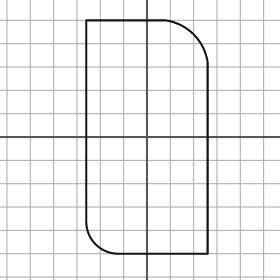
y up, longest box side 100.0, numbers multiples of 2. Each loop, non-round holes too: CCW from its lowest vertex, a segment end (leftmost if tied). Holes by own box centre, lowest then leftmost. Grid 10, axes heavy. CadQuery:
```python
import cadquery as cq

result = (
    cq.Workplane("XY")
    .moveTo(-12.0, -50.0)
    .lineTo(26.0, -50.0)
    .lineTo(26.0, 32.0)
    .threePointArc((20.0, 44.0), (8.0, 50.0))
    .lineTo(-26.0, 50.0)
    .lineTo(-26.0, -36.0)
    .threePointArc((-22.0, -46.0), (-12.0, -50.0))
    .close()
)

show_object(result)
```